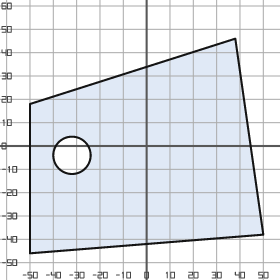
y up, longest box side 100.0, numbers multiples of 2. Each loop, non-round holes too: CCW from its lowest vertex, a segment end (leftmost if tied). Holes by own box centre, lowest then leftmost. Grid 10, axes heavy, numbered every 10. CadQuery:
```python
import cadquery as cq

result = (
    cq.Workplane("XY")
    .moveTo(-50.0, -46.0)
    .lineTo(50.0, -38.0)
    .lineTo(38.0, 46.0)
    .lineTo(-50.0, 18.0)
    .close()
    .moveTo(-32.0, -4.0)
    .circle(8.0)
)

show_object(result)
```